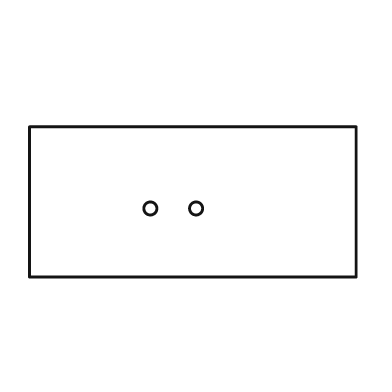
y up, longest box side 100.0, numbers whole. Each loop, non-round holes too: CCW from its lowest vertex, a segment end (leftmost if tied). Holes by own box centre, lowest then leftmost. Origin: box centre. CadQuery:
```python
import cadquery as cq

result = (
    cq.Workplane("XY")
    .moveTo(-50.0, -23.0)
    .lineTo(50.0, -23.0)
    .lineTo(50.0, 23.0)
    .lineTo(-50.0, 23.0)
    .close()
    .moveTo(-13.0, -2.0)
    .circle(2.0)
    .moveTo(1.0, -2.0)
    .circle(2.0)
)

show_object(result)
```